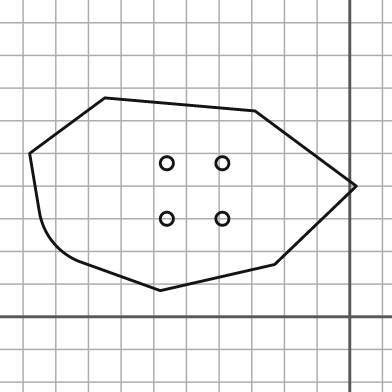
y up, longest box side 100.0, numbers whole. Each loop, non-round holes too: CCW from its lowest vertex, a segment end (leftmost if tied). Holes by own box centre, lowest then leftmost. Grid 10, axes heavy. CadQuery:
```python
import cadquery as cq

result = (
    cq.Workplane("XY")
    .moveTo(-58.0, 8.0)
    .lineTo(-23.0, 16.0)
    .lineTo(2.0, 40.0)
    .lineTo(-29.0, 63.0)
    .lineTo(-75.0, 67.0)
    .lineTo(-98.0, 50.0)
    .lineTo(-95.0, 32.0)
    .threePointArc((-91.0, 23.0), (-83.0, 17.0))
    .close()
    .moveTo(-56.0, 30.0)
    .circle(2.0)
    .moveTo(-39.0, 30.0)
    .circle(2.0)
    .moveTo(-56.0, 47.0)
    .circle(2.0)
    .moveTo(-39.0, 47.0)
    .circle(2.0)
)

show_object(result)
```